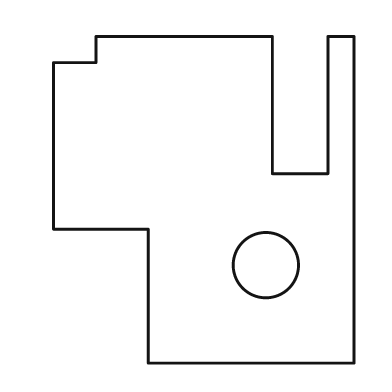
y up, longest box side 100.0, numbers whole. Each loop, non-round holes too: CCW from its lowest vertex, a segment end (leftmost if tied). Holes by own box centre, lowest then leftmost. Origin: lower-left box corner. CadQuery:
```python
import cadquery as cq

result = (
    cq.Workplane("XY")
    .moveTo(29.0, 0.0)
    .lineTo(92.0, 0.0)
    .lineTo(92.0, 100.0)
    .lineTo(84.0, 100.0)
    .lineTo(84.0, 58.0)
    .lineTo(67.0, 58.0)
    .lineTo(67.0, 100.0)
    .lineTo(13.0, 100.0)
    .lineTo(13.0, 92.0)
    .lineTo(0.0, 92.0)
    .lineTo(0.0, 41.0)
    .lineTo(29.0, 41.0)
    .close()
    .moveTo(65.0, 30.0)
    .circle(10.0)
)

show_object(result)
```